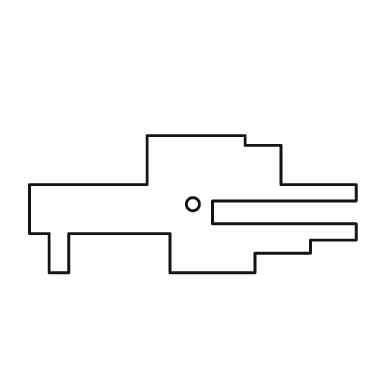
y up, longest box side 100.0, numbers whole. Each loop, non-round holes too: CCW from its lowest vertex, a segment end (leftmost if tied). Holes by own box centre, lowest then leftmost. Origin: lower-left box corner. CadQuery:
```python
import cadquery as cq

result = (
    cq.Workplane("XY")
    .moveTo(6.0, 0.0)
    .lineTo(12.0, 0.0)
    .lineTo(12.0, 12.0)
    .lineTo(43.0, 12.0)
    .lineTo(43.0, 0.0)
    .lineTo(69.0, 0.0)
    .lineTo(69.0, 6.0)
    .lineTo(86.0, 6.0)
    .lineTo(86.0, 10.0)
    .lineTo(100.0, 10.0)
    .lineTo(100.0, 15.0)
    .lineTo(56.0, 15.0)
    .lineTo(56.0, 22.0)
    .lineTo(100.0, 22.0)
    .lineTo(100.0, 27.0)
    .lineTo(77.0, 27.0)
    .lineTo(77.0, 39.0)
    .lineTo(66.0, 39.0)
    .lineTo(66.0, 42.0)
    .lineTo(36.0, 42.0)
    .lineTo(36.0, 27.0)
    .lineTo(0.0, 27.0)
    .lineTo(0.0, 12.0)
    .lineTo(6.0, 12.0)
    .close()
    .moveTo(50.0, 21.0)
    .circle(2.0)
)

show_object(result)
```